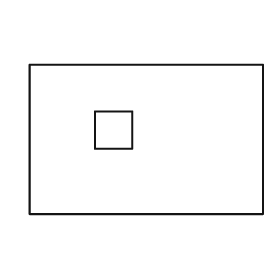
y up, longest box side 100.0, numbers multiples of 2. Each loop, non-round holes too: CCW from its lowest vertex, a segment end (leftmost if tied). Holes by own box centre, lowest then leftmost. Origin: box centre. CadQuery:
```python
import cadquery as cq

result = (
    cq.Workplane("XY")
    .moveTo(-50.0, -32.0)
    .lineTo(50.0, -32.0)
    .lineTo(50.0, 32.0)
    .lineTo(-50.0, 32.0)
    .close()
    .moveTo(-22.0, -4.0)
    .lineTo(-6.0, -4.0)
    .lineTo(-6.0, 12.0)
    .lineTo(-22.0, 12.0)
    .close()
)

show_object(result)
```